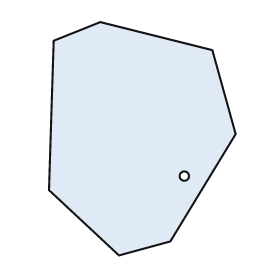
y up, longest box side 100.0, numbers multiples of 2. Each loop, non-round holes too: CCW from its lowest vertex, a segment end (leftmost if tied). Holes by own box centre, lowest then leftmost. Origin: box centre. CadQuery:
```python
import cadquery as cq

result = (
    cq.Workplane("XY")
    .moveTo(-10.0, -50.0)
    .lineTo(12.0, -44.0)
    .lineTo(40.0, 2.0)
    .lineTo(30.0, 38.0)
    .lineTo(-18.0, 50.0)
    .lineTo(-38.0, 42.0)
    .lineTo(-40.0, -22.0)
    .close()
    .moveTo(18.0, -16.0)
    .circle(2.0)
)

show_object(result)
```